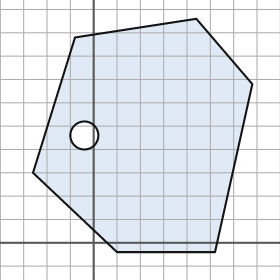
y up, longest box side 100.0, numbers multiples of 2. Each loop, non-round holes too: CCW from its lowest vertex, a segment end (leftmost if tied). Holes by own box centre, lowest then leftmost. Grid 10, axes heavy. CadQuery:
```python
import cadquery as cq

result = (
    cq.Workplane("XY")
    .moveTo(10.0, -4.0)
    .lineTo(52.0, -4.0)
    .lineTo(68.0, 68.0)
    .lineTo(44.0, 96.0)
    .lineTo(-8.0, 88.0)
    .lineTo(-26.0, 30.0)
    .close()
    .moveTo(-4.0, 46.0)
    .circle(6.0)
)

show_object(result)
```